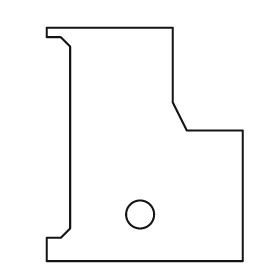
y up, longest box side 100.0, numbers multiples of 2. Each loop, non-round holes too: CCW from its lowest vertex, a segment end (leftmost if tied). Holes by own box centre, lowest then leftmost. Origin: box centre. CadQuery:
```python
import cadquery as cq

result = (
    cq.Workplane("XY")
    .moveTo(-42.0, -50.0)
    .lineTo(42.0, -50.0)
    .lineTo(42.0, 6.0)
    .lineTo(18.0, 6.0)
    .lineTo(12.0, 18.0)
    .lineTo(12.0, 50.0)
    .lineTo(-42.0, 50.0)
    .lineTo(-42.0, 46.0)
    .lineTo(-36.0, 46.0)
    .lineTo(-32.0, 42.0)
    .lineTo(-32.0, -36.0)
    .lineTo(-36.0, -40.0)
    .lineTo(-42.0, -40.0)
    .close()
    .moveTo(-2.0, -30.0)
    .circle(6.0)
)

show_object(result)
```